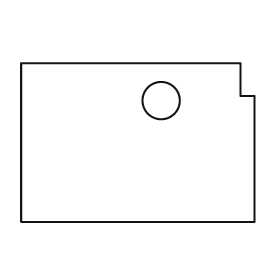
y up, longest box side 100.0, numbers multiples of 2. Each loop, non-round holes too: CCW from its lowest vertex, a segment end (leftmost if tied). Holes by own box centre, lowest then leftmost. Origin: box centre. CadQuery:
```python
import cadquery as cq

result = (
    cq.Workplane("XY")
    .moveTo(-50.0, -34.0)
    .lineTo(50.0, -34.0)
    .lineTo(50.0, 20.0)
    .lineTo(44.0, 20.0)
    .lineTo(44.0, 34.0)
    .lineTo(-50.0, 34.0)
    .close()
    .moveTo(10.0, 18.0)
    .circle(8.0)
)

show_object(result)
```